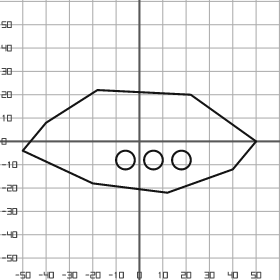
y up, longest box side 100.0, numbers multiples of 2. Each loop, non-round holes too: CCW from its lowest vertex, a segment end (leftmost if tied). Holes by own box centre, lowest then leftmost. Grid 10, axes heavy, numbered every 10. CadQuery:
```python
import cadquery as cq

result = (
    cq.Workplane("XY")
    .moveTo(12.0, -22.0)
    .lineTo(40.0, -12.0)
    .lineTo(50.0, 0.0)
    .lineTo(22.0, 20.0)
    .lineTo(-18.0, 22.0)
    .lineTo(-40.0, 8.0)
    .lineTo(-50.0, -4.0)
    .lineTo(-20.0, -18.0)
    .close()
    .moveTo(-6.0, -8.0)
    .circle(4.0)
    .moveTo(6.0, -8.0)
    .circle(4.0)
    .moveTo(18.0, -8.0)
    .circle(4.0)
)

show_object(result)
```